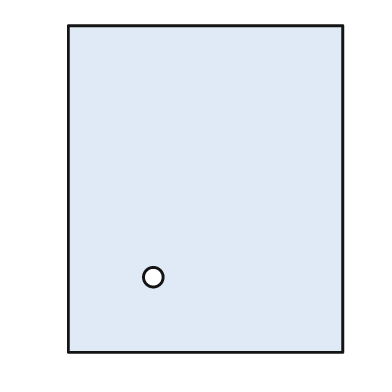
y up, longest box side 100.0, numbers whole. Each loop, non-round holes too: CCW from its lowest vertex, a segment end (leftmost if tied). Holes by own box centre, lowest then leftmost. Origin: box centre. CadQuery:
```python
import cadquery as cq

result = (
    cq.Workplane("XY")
    .moveTo(-42.0, -50.0)
    .lineTo(42.0, -50.0)
    .lineTo(42.0, 50.0)
    .lineTo(-42.0, 50.0)
    .close()
    .moveTo(-16.0, -27.0)
    .circle(3.0)
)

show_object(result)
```